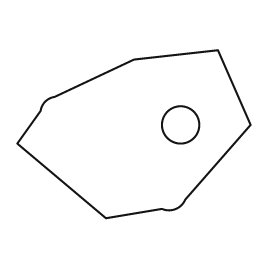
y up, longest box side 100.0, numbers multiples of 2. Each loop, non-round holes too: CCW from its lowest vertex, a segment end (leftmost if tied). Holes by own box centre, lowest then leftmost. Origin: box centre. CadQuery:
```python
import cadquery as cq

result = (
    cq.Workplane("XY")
    .moveTo(-12.0, -36.0)
    .lineTo(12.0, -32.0)
    .threePointArc((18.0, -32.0), (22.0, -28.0))
    .lineTo(50.0, 4.0)
    .lineTo(36.0, 36.0)
    .lineTo(0.0, 32.0)
    .lineTo(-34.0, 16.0)
    .threePointArc((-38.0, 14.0), (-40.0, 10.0))
    .lineTo(-50.0, -4.0)
    .close()
    .moveTo(20.0, 4.0)
    .circle(8.0)
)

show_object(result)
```